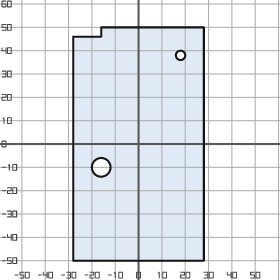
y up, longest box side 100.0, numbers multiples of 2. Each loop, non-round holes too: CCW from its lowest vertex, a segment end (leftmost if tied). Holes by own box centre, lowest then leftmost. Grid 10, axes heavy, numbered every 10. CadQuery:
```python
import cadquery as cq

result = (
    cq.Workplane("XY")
    .moveTo(-28.0, -50.0)
    .lineTo(28.0, -50.0)
    .lineTo(28.0, 50.0)
    .lineTo(-16.0, 50.0)
    .lineTo(-16.0, 46.0)
    .lineTo(-28.0, 46.0)
    .close()
    .moveTo(-16.0, -10.0)
    .circle(4.0)
    .moveTo(18.0, 38.0)
    .circle(2.0)
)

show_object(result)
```